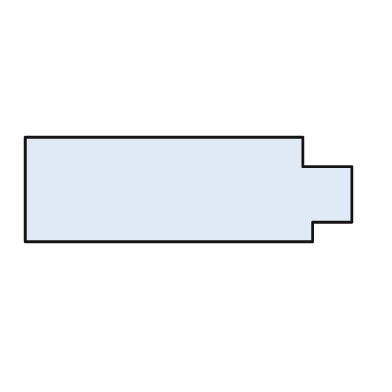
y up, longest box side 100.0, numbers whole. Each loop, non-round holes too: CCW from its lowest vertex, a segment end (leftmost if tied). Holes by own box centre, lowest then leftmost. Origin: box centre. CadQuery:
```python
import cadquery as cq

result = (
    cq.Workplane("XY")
    .moveTo(-50.0, -16.0)
    .lineTo(38.0, -16.0)
    .lineTo(38.0, -10.0)
    .lineTo(50.0, -10.0)
    .lineTo(50.0, 7.0)
    .lineTo(35.0, 7.0)
    .lineTo(35.0, 16.0)
    .lineTo(-50.0, 16.0)
    .close()
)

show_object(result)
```